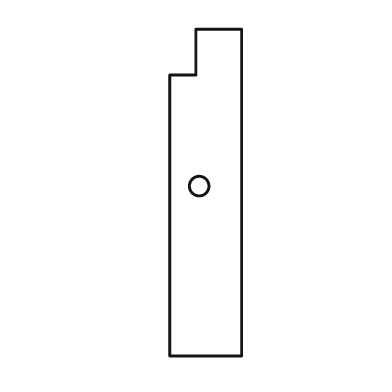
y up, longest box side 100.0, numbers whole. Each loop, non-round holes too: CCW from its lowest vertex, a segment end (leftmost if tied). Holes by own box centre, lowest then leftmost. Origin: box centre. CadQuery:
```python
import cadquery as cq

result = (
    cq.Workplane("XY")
    .moveTo(-11.0, -50.0)
    .lineTo(11.0, -50.0)
    .lineTo(11.0, 50.0)
    .lineTo(-3.0, 50.0)
    .lineTo(-3.0, 36.0)
    .lineTo(-11.0, 36.0)
    .close()
    .moveTo(-2.0, 2.0)
    .circle(3.0)
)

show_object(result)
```